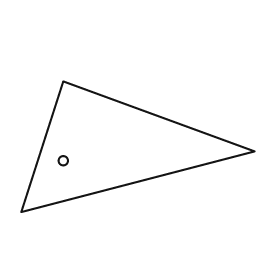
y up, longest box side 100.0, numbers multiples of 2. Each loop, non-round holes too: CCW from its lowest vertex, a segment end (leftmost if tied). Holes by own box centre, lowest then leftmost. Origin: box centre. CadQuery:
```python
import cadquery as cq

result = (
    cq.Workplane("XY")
    .moveTo(-50.0, -28.0)
    .lineTo(50.0, -2.0)
    .lineTo(-32.0, 28.0)
    .close()
    .moveTo(-32.0, -6.0)
    .circle(2.0)
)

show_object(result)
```